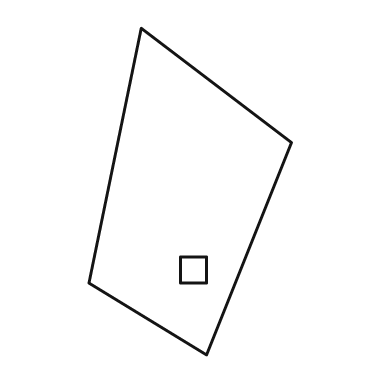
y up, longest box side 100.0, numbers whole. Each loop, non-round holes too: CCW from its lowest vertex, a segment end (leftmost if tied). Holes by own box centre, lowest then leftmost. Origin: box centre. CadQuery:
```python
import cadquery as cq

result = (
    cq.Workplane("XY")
    .moveTo(5.0, -50.0)
    .lineTo(31.0, 15.0)
    .lineTo(-15.0, 50.0)
    .lineTo(-31.0, -28.0)
    .close()
    .moveTo(-3.0, -28.0)
    .lineTo(5.0, -28.0)
    .lineTo(5.0, -20.0)
    .lineTo(-3.0, -20.0)
    .close()
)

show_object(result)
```